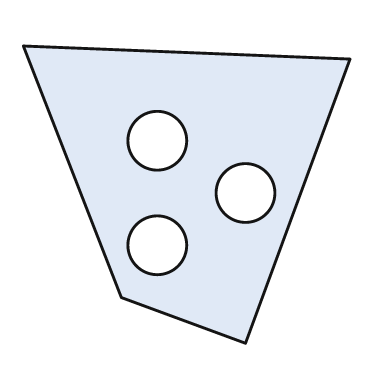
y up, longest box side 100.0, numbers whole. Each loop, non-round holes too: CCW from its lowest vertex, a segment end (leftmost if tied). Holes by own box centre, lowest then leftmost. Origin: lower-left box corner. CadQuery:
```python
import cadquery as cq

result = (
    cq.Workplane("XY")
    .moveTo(68.0, 0.0)
    .lineTo(100.0, 87.0)
    .lineTo(0.0, 91.0)
    .lineTo(30.0, 14.0)
    .close()
    .moveTo(41.0, 30.0)
    .circle(9.0)
    .moveTo(68.0, 46.0)
    .circle(9.0)
    .moveTo(41.0, 62.0)
    .circle(9.0)
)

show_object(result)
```